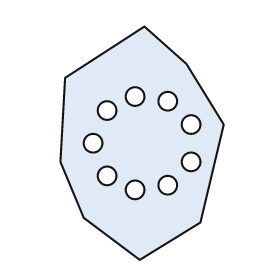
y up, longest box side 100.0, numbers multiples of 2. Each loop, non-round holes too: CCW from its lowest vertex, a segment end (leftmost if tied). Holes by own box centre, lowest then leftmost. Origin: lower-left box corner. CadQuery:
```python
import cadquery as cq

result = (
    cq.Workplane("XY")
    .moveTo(34.0, 0.0)
    .lineTo(60.0, 16.0)
    .lineTo(70.0, 58.0)
    .lineTo(54.0, 84.0)
    .lineTo(36.0, 100.0)
    .lineTo(2.0, 78.0)
    .lineTo(0.0, 42.0)
    .lineTo(10.0, 18.0)
    .close()
    .moveTo(32.0, 30.0)
    .circle(4.0)
    .moveTo(46.0, 32.0)
    .circle(4.0)
    .moveTo(20.0, 36.0)
    .circle(4.0)
    .moveTo(56.0, 42.0)
    .circle(4.0)
    .moveTo(14.0, 50.0)
    .circle(4.0)
    .moveTo(56.0, 58.0)
    .circle(4.0)
    .moveTo(20.0, 64.0)
    .circle(4.0)
    .moveTo(46.0, 68.0)
    .circle(4.0)
    .moveTo(32.0, 70.0)
    .circle(4.0)
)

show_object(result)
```